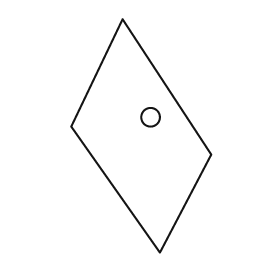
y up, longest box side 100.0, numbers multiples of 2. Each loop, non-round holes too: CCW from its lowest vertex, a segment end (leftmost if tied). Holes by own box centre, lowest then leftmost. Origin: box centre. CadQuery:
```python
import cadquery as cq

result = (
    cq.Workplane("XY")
    .moveTo(8.0, -50.0)
    .lineTo(30.0, -8.0)
    .lineTo(-8.0, 50.0)
    .lineTo(-30.0, 4.0)
    .close()
    .moveTo(4.0, 8.0)
    .circle(4.0)
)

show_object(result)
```